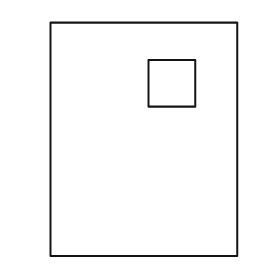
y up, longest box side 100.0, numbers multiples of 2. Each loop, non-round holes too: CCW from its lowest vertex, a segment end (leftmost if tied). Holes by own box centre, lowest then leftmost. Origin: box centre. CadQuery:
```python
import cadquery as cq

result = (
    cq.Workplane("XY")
    .moveTo(-40.0, -50.0)
    .lineTo(40.0, -50.0)
    .lineTo(40.0, 50.0)
    .lineTo(-40.0, 50.0)
    .close()
    .moveTo(2.0, 14.0)
    .lineTo(22.0, 14.0)
    .lineTo(22.0, 34.0)
    .lineTo(2.0, 34.0)
    .close()
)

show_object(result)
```